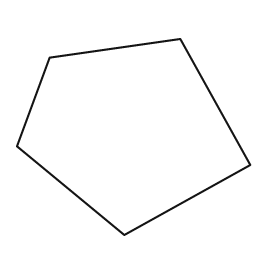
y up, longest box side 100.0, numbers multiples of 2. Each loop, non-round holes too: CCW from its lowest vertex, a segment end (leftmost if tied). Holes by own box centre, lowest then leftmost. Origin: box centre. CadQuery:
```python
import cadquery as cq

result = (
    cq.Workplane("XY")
    .moveTo(-4.0, -42.0)
    .lineTo(50.0, -12.0)
    .lineTo(20.0, 42.0)
    .lineTo(-36.0, 34.0)
    .lineTo(-50.0, -4.0)
    .close()
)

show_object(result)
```